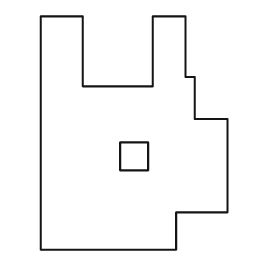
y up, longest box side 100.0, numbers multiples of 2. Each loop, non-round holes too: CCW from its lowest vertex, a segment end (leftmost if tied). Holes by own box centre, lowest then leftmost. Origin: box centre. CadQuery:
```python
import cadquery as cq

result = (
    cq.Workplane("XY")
    .moveTo(-40.0, -50.0)
    .lineTo(18.0, -50.0)
    .lineTo(18.0, -34.0)
    .lineTo(40.0, -34.0)
    .lineTo(40.0, 6.0)
    .lineTo(26.0, 6.0)
    .lineTo(26.0, 24.0)
    .lineTo(22.0, 24.0)
    .lineTo(22.0, 50.0)
    .lineTo(8.0, 50.0)
    .lineTo(8.0, 20.0)
    .lineTo(-22.0, 20.0)
    .lineTo(-22.0, 50.0)
    .lineTo(-40.0, 50.0)
    .close()
    .moveTo(-6.0, -16.0)
    .lineTo(6.0, -16.0)
    .lineTo(6.0, -4.0)
    .lineTo(-6.0, -4.0)
    .close()
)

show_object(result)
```